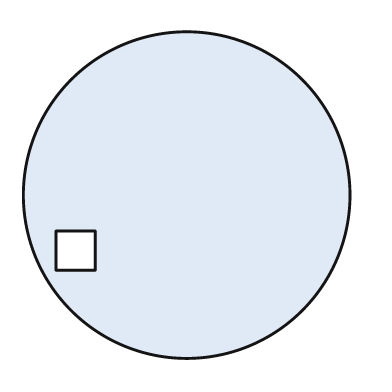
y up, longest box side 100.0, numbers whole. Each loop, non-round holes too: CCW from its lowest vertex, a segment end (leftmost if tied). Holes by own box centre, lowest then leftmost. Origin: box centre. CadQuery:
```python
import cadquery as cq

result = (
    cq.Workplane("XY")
    .moveTo(0.0, 0.0)
    .circle(50.0)
    .moveTo(-40.0, -23.0)
    .lineTo(-28.0, -23.0)
    .lineTo(-28.0, -11.0)
    .lineTo(-40.0, -11.0)
    .close()
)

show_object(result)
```